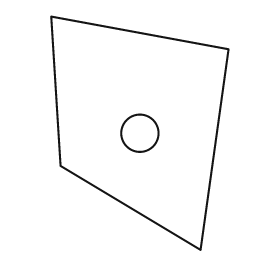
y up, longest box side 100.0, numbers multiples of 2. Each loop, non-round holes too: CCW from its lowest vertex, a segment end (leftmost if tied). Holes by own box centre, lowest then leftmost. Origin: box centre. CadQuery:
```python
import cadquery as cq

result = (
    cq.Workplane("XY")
    .moveTo(26.0, -50.0)
    .lineTo(38.0, 36.0)
    .lineTo(-38.0, 50.0)
    .lineTo(-34.0, -14.0)
    .close()
    .moveTo(0.0, 0.0)
    .circle(8.0)
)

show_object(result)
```